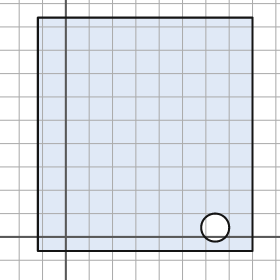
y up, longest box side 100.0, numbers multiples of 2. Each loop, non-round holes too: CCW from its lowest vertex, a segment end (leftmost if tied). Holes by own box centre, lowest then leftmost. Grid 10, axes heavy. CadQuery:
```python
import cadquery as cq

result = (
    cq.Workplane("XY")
    .moveTo(-12.0, -6.0)
    .lineTo(80.0, -6.0)
    .lineTo(80.0, 94.0)
    .lineTo(-12.0, 94.0)
    .close()
    .moveTo(64.0, 4.0)
    .circle(6.0)
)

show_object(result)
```